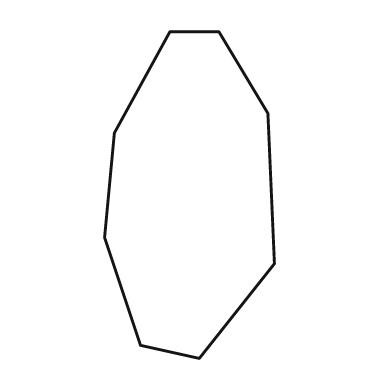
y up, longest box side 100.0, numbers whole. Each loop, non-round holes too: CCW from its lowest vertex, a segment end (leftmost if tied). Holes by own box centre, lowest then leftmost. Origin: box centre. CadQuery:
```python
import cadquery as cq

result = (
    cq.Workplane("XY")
    .moveTo(3.0, -50.0)
    .lineTo(26.0, -21.0)
    .lineTo(24.0, 25.0)
    .lineTo(9.0, 50.0)
    .lineTo(-6.0, 50.0)
    .lineTo(-23.0, 19.0)
    .lineTo(-26.0, -13.0)
    .lineTo(-15.0, -46.0)
    .close()
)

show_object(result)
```